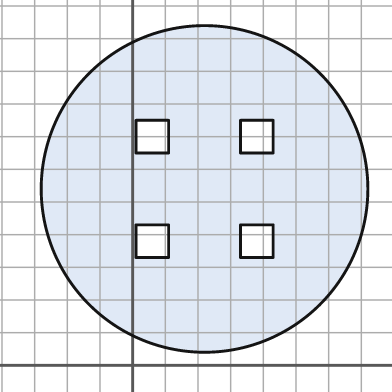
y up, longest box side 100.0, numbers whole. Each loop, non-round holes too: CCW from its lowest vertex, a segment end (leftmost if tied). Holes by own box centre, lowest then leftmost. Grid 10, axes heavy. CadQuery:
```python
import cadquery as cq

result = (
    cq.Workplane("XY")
    .moveTo(22.0, 54.0)
    .circle(50.0)
    .moveTo(1.0, 33.0)
    .lineTo(11.0, 33.0)
    .lineTo(11.0, 43.0)
    .lineTo(1.0, 43.0)
    .close()
    .moveTo(33.0, 33.0)
    .lineTo(43.0, 33.0)
    .lineTo(43.0, 43.0)
    .lineTo(33.0, 43.0)
    .close()
    .moveTo(1.0, 65.0)
    .lineTo(11.0, 65.0)
    .lineTo(11.0, 75.0)
    .lineTo(1.0, 75.0)
    .close()
    .moveTo(33.0, 65.0)
    .lineTo(43.0, 65.0)
    .lineTo(43.0, 75.0)
    .lineTo(33.0, 75.0)
    .close()
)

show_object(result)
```